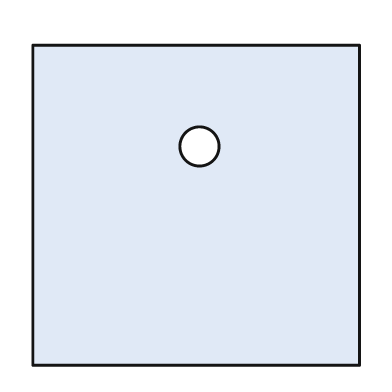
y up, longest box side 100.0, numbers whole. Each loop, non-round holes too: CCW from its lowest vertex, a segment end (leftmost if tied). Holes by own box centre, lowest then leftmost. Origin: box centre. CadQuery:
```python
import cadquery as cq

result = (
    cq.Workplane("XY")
    .moveTo(-50.0, -49.0)
    .lineTo(50.0, -49.0)
    .lineTo(50.0, 49.0)
    .lineTo(-50.0, 49.0)
    .close()
    .moveTo(1.0, 18.0)
    .circle(6.0)
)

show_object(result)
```